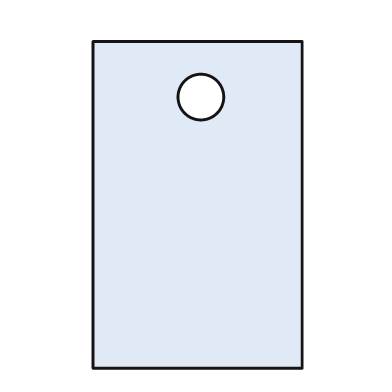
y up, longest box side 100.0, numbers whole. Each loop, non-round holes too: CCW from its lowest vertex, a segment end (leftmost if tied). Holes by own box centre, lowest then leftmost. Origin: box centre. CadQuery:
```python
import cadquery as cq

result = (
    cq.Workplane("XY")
    .moveTo(-32.0, -50.0)
    .lineTo(32.0, -50.0)
    .lineTo(32.0, 50.0)
    .lineTo(-32.0, 50.0)
    .close()
    .moveTo(1.0, 33.0)
    .circle(7.0)
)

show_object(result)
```